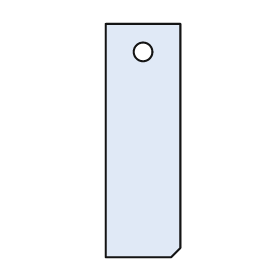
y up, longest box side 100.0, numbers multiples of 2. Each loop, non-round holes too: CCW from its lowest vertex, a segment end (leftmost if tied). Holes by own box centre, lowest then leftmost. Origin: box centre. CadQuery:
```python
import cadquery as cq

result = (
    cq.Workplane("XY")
    .moveTo(-16.0, -50.0)
    .lineTo(12.0, -50.0)
    .lineTo(16.0, -46.0)
    .lineTo(16.0, 50.0)
    .lineTo(-16.0, 50.0)
    .close()
    .moveTo(0.0, 38.0)
    .circle(4.0)
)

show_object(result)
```